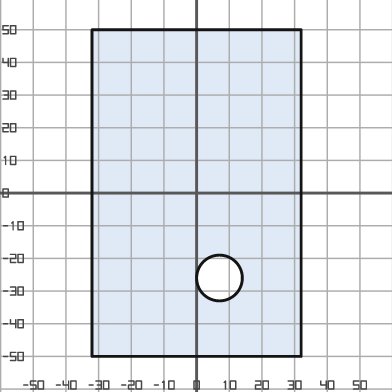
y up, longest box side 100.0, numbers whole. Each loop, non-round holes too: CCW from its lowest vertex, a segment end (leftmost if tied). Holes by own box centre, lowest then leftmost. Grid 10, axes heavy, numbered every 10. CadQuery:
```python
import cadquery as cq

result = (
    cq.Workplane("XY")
    .moveTo(-32.0, -50.0)
    .lineTo(32.0, -50.0)
    .lineTo(32.0, 50.0)
    .lineTo(-32.0, 50.0)
    .close()
    .moveTo(7.0, -26.0)
    .circle(7.0)
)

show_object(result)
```